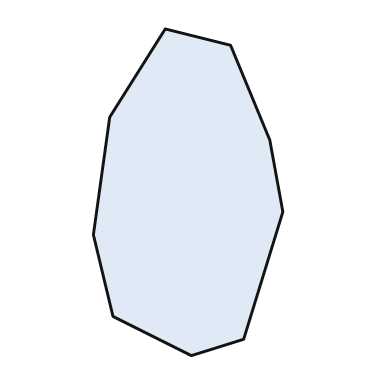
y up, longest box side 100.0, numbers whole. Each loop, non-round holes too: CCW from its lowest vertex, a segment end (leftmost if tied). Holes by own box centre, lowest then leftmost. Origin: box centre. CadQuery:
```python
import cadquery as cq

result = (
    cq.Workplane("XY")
    .moveTo(1.0, -50.0)
    .lineTo(17.0, -45.0)
    .lineTo(29.0, -6.0)
    .lineTo(25.0, 16.0)
    .lineTo(13.0, 45.0)
    .lineTo(-7.0, 50.0)
    .lineTo(-24.0, 23.0)
    .lineTo(-29.0, -13.0)
    .lineTo(-23.0, -38.0)
    .close()
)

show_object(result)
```